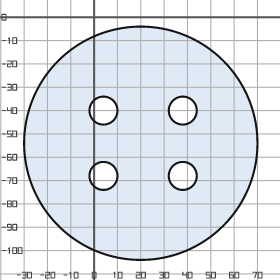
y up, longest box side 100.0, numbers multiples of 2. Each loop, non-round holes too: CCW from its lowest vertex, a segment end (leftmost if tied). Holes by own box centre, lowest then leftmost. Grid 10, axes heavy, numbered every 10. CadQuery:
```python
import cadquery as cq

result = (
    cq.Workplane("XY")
    .moveTo(20.0, -54.0)
    .circle(50.0)
    .moveTo(4.0, -68.0)
    .circle(6.0)
    .moveTo(38.0, -68.0)
    .circle(6.0)
    .moveTo(4.0, -40.0)
    .circle(6.0)
    .moveTo(38.0, -40.0)
    .circle(6.0)
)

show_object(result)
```